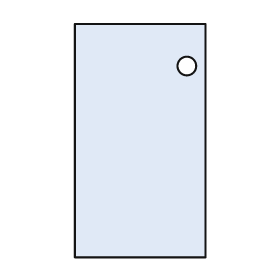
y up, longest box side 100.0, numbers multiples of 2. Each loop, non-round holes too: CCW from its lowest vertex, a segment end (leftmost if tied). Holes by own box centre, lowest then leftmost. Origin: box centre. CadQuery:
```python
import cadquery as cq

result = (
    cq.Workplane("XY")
    .moveTo(-28.0, -50.0)
    .lineTo(28.0, -50.0)
    .lineTo(28.0, 50.0)
    .lineTo(-28.0, 50.0)
    .close()
    .moveTo(20.0, 32.0)
    .circle(4.0)
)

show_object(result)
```